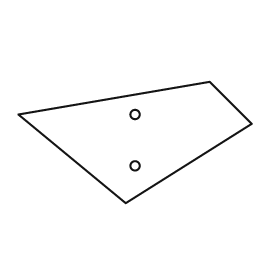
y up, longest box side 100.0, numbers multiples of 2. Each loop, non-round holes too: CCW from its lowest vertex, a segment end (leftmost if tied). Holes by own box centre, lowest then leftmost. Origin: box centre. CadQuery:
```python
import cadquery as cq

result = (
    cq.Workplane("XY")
    .moveTo(-4.0, -26.0)
    .lineTo(50.0, 8.0)
    .lineTo(32.0, 26.0)
    .lineTo(-50.0, 12.0)
    .close()
    .moveTo(0.0, -10.0)
    .circle(2.0)
    .moveTo(0.0, 12.0)
    .circle(2.0)
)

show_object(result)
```